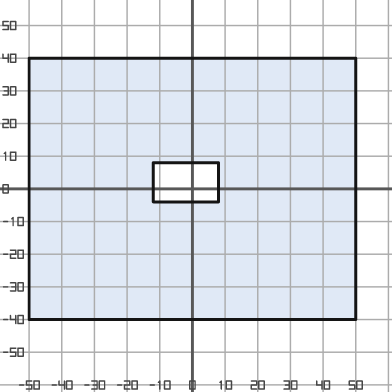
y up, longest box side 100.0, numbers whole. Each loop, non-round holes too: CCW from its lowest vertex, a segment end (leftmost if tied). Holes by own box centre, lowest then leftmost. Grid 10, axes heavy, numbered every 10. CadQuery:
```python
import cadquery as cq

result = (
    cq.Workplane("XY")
    .moveTo(-50.0, -40.0)
    .lineTo(50.0, -40.0)
    .lineTo(50.0, 40.0)
    .lineTo(-50.0, 40.0)
    .close()
    .moveTo(-12.0, -4.0)
    .lineTo(8.0, -4.0)
    .lineTo(8.0, 8.0)
    .lineTo(-12.0, 8.0)
    .close()
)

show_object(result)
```